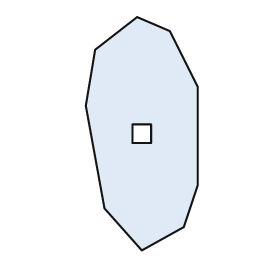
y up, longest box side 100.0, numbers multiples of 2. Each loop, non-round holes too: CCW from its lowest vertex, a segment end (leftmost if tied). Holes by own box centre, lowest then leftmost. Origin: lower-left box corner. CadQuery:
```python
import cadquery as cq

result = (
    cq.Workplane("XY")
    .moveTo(24.0, 0.0)
    .lineTo(42.0, 10.0)
    .lineTo(48.0, 28.0)
    .lineTo(48.0, 70.0)
    .lineTo(36.0, 94.0)
    .lineTo(22.0, 100.0)
    .lineTo(4.0, 86.0)
    .lineTo(0.0, 62.0)
    .lineTo(8.0, 18.0)
    .close()
    .moveTo(20.0, 46.0)
    .lineTo(28.0, 46.0)
    .lineTo(28.0, 54.0)
    .lineTo(20.0, 54.0)
    .close()
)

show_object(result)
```